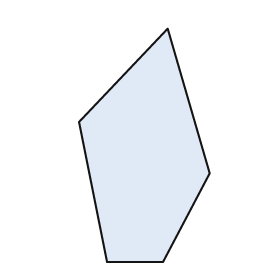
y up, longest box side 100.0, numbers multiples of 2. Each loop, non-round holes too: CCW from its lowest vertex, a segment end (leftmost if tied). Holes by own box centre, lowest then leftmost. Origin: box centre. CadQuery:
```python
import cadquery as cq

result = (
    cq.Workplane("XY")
    .moveTo(-16.0, -50.0)
    .lineTo(8.0, -50.0)
    .lineTo(28.0, -12.0)
    .lineTo(10.0, 50.0)
    .lineTo(-28.0, 10.0)
    .close()
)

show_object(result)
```